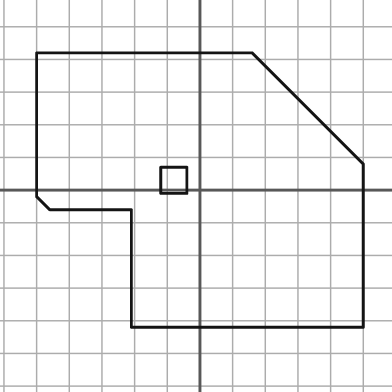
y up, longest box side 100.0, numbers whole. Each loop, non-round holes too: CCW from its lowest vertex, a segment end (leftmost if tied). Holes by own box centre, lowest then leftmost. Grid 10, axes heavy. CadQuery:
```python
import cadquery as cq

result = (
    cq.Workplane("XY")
    .moveTo(-21.0, -42.0)
    .lineTo(50.0, -42.0)
    .lineTo(50.0, 8.0)
    .lineTo(16.0, 42.0)
    .lineTo(-50.0, 42.0)
    .lineTo(-50.0, -2.0)
    .lineTo(-46.0, -6.0)
    .lineTo(-21.0, -6.0)
    .close()
    .moveTo(-12.0, -1.0)
    .lineTo(-4.0, -1.0)
    .lineTo(-4.0, 7.0)
    .lineTo(-12.0, 7.0)
    .close()
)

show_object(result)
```